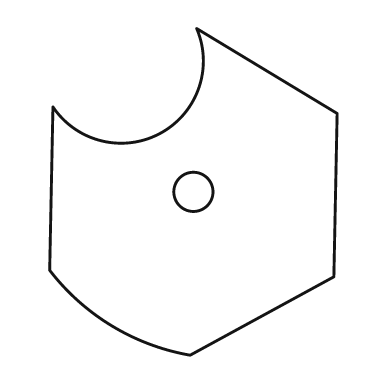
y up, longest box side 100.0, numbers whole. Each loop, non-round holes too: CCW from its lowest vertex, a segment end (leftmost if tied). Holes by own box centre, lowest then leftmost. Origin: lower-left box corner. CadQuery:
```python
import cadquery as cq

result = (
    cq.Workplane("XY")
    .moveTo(43.0, 0.0)
    .lineTo(87.0, 24.0)
    .lineTo(88.0, 74.0)
    .lineTo(45.0, 100.0)
    .threePointArc((34.0, 68.0), (1.0, 76.0))
    .lineTo(0.0, 26.0)
    .threePointArc((19.0, 9.0), (43.0, 0.0))
    .close()
    .moveTo(44.0, 50.0)
    .circle(6.0)
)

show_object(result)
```